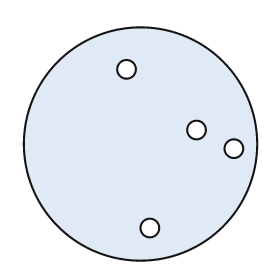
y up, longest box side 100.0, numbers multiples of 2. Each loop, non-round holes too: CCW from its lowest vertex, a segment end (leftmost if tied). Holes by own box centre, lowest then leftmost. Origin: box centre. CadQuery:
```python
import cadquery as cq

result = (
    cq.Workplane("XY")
    .moveTo(0.0, 0.0)
    .circle(50.0)
    .moveTo(4.0, -36.0)
    .circle(4.0)
    .moveTo(40.0, -2.0)
    .circle(4.0)
    .moveTo(24.0, 6.0)
    .circle(4.0)
    .moveTo(-6.0, 32.0)
    .circle(4.0)
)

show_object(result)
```